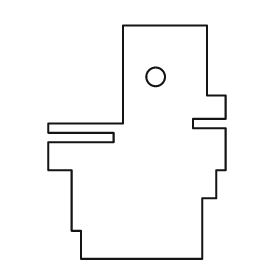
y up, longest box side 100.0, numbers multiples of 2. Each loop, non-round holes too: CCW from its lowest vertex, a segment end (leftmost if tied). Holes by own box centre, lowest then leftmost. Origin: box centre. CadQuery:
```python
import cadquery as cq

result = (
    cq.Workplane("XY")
    .moveTo(-24.0, -50.0)
    .lineTo(28.0, -50.0)
    .lineTo(28.0, -24.0)
    .lineTo(34.0, -24.0)
    .lineTo(34.0, -12.0)
    .lineTo(38.0, -12.0)
    .lineTo(38.0, 6.0)
    .lineTo(24.0, 6.0)
    .lineTo(24.0, 10.0)
    .lineTo(38.0, 10.0)
    .lineTo(38.0, 20.0)
    .lineTo(30.0, 20.0)
    .lineTo(30.0, 50.0)
    .lineTo(-6.0, 50.0)
    .lineTo(-6.0, 8.0)
    .lineTo(-38.0, 8.0)
    .lineTo(-38.0, 4.0)
    .lineTo(-10.0, 4.0)
    .lineTo(-10.0, 0.0)
    .lineTo(-38.0, 0.0)
    .lineTo(-38.0, -12.0)
    .lineTo(-28.0, -12.0)
    .lineTo(-28.0, -38.0)
    .lineTo(-24.0, -38.0)
    .close()
    .moveTo(8.0, 28.0)
    .circle(4.0)
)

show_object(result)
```